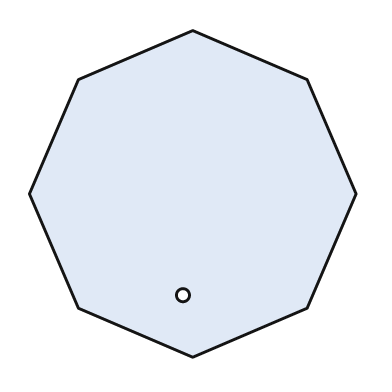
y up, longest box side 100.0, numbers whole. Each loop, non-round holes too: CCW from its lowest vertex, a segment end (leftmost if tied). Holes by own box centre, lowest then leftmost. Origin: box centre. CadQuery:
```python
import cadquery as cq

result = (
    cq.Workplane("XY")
    .moveTo(0.0, -50.0)
    .lineTo(35.0, -35.0)
    .lineTo(50.0, 0.0)
    .lineTo(35.0, 35.0)
    .lineTo(0.0, 50.0)
    .lineTo(-35.0, 35.0)
    .lineTo(-50.0, 0.0)
    .lineTo(-35.0, -35.0)
    .close()
    .moveTo(-3.0, -31.0)
    .circle(2.0)
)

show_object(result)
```